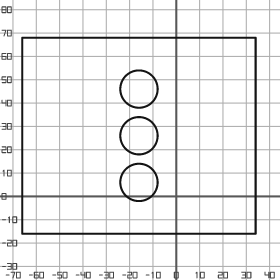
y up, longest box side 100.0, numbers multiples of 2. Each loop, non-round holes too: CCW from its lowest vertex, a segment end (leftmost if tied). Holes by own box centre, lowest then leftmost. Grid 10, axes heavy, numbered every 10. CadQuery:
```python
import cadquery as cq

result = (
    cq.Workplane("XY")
    .moveTo(-66.0, -16.0)
    .lineTo(34.0, -16.0)
    .lineTo(34.0, 68.0)
    .lineTo(-66.0, 68.0)
    .close()
    .moveTo(-16.0, 6.0)
    .circle(8.0)
    .moveTo(-16.0, 26.0)
    .circle(8.0)
    .moveTo(-16.0, 46.0)
    .circle(8.0)
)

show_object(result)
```